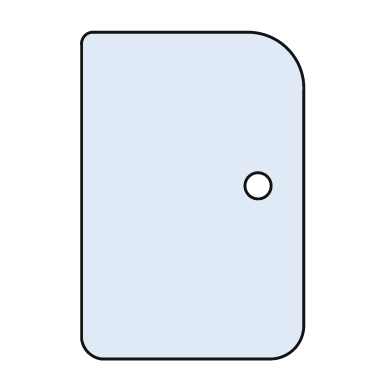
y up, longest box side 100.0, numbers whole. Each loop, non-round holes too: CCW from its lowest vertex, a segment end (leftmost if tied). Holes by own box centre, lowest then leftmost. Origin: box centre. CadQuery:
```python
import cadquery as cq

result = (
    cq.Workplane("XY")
    .moveTo(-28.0, -50.0)
    .lineTo(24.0, -50.0)
    .threePointArc((31.0, -47.0), (34.0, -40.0))
    .lineTo(34.0, 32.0)
    .threePointArc((29.0, 45.0), (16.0, 50.0))
    .lineTo(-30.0, 50.0)
    .threePointArc((-33.0, 49.0), (-34.0, 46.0))
    .lineTo(-34.0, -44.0)
    .threePointArc((-32.0, -48.0), (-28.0, -50.0))
    .close()
    .moveTo(20.0, 3.0)
    .circle(4.0)
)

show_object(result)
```